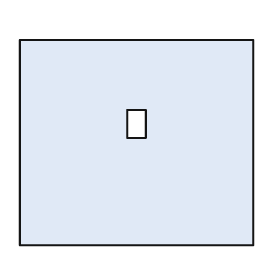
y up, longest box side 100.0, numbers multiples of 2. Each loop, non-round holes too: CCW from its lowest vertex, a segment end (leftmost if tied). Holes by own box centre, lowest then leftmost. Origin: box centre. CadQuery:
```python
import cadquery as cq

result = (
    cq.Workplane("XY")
    .moveTo(-50.0, -44.0)
    .lineTo(50.0, -44.0)
    .lineTo(50.0, 44.0)
    .lineTo(-50.0, 44.0)
    .close()
    .moveTo(-4.0, 2.0)
    .lineTo(4.0, 2.0)
    .lineTo(4.0, 14.0)
    .lineTo(-4.0, 14.0)
    .close()
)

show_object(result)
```